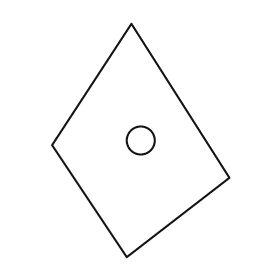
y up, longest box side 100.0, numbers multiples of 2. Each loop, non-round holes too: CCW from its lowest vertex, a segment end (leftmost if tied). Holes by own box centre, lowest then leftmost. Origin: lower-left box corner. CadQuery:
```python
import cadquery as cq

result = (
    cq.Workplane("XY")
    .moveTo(32.0, 0.0)
    .lineTo(76.0, 34.0)
    .lineTo(34.0, 100.0)
    .lineTo(0.0, 48.0)
    .close()
    .moveTo(38.0, 50.0)
    .circle(6.0)
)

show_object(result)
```